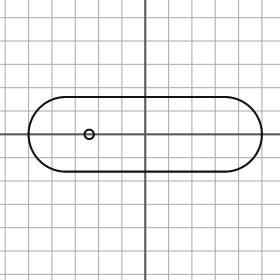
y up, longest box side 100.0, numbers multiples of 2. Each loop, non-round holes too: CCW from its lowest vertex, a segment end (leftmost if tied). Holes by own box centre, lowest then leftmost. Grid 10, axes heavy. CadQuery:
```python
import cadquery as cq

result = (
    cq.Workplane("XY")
    .moveTo(-34.0, -16.0)
    .lineTo(34.0, -16.0)
    .threePointArc((50.0, 0.0), (34.0, 16.0))
    .lineTo(-34.0, 16.0)
    .threePointArc((-50.0, 0.0), (-34.0, -16.0))
    .close()
    .moveTo(-24.0, 0.0)
    .circle(2.0)
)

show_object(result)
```